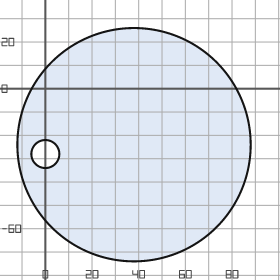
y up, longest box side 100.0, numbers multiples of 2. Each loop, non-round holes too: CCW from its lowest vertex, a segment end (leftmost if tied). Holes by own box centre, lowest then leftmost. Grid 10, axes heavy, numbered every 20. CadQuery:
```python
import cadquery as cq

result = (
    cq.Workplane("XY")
    .moveTo(38.0, -24.0)
    .circle(50.0)
    .moveTo(0.0, -28.0)
    .circle(6.0)
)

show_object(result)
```